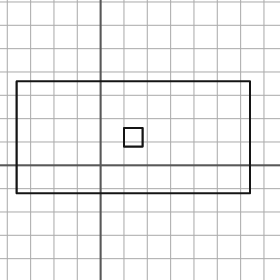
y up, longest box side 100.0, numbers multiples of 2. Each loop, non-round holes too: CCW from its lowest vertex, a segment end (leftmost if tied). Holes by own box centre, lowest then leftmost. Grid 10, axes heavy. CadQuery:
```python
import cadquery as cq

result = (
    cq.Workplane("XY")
    .moveTo(-36.0, -12.0)
    .lineTo(64.0, -12.0)
    .lineTo(64.0, 36.0)
    .lineTo(-36.0, 36.0)
    .close()
    .moveTo(10.0, 8.0)
    .lineTo(18.0, 8.0)
    .lineTo(18.0, 16.0)
    .lineTo(10.0, 16.0)
    .close()
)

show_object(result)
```